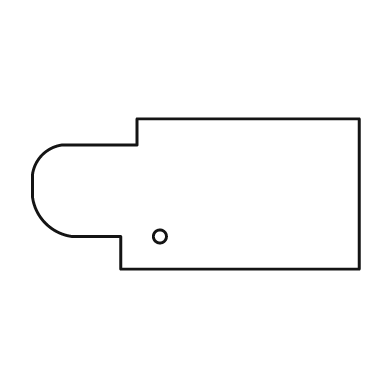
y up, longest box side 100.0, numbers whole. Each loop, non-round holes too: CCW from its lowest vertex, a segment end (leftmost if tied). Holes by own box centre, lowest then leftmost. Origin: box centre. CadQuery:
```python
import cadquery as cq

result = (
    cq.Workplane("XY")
    .moveTo(-23.0, -23.0)
    .lineTo(50.0, -23.0)
    .lineTo(50.0, 23.0)
    .lineTo(-18.0, 23.0)
    .lineTo(-18.0, 15.0)
    .lineTo(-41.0, 15.0)
    .threePointArc((-47.0, 12.0), (-50.0, 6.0))
    .lineTo(-50.0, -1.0)
    .threePointArc((-46.0, -9.0), (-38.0, -13.0))
    .lineTo(-23.0, -13.0)
    .close()
    .moveTo(-11.0, -13.0)
    .circle(2.0)
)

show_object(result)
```